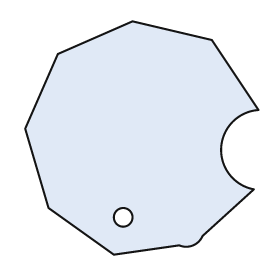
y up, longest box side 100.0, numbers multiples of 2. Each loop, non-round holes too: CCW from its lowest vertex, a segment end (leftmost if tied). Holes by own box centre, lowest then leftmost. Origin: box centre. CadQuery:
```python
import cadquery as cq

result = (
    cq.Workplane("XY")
    .moveTo(-12.0, -50.0)
    .lineTo(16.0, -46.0)
    .threePointArc((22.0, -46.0), (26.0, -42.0))
    .lineTo(48.0, -22.0)
    .threePointArc((34.0, -4.0), (50.0, 12.0))
    .lineTo(30.0, 42.0)
    .lineTo(-4.0, 50.0)
    .lineTo(-36.0, 36.0)
    .lineTo(-50.0, 4.0)
    .lineTo(-40.0, -30.0)
    .close()
    .moveTo(-8.0, -34.0)
    .circle(4.0)
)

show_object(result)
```